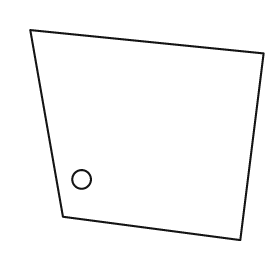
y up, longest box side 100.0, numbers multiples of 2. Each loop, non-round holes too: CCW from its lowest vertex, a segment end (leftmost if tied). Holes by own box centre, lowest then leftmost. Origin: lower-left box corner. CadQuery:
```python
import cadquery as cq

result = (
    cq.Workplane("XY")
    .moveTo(90.0, 0.0)
    .lineTo(100.0, 80.0)
    .lineTo(0.0, 90.0)
    .lineTo(14.0, 10.0)
    .close()
    .moveTo(22.0, 26.0)
    .circle(4.0)
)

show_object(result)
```